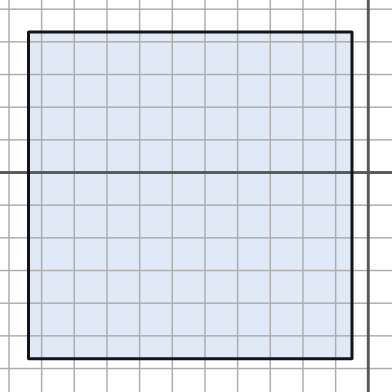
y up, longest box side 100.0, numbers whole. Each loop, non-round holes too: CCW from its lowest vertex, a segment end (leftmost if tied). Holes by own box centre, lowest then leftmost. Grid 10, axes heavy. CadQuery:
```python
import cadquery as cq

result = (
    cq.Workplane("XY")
    .moveTo(-104.0, -57.0)
    .lineTo(-5.0, -57.0)
    .lineTo(-5.0, 43.0)
    .lineTo(-104.0, 43.0)
    .close()
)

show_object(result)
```